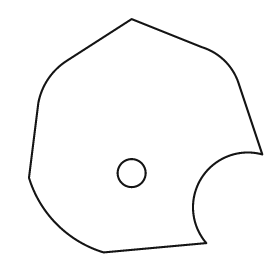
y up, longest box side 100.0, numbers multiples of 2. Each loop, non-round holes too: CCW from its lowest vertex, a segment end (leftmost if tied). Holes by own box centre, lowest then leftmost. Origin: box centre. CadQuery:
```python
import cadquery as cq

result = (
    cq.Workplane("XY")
    .moveTo(-18.0, -50.0)
    .lineTo(26.0, -46.0)
    .threePointArc((24.0, -18.0), (50.0, -8.0))
    .lineTo(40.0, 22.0)
    .threePointArc((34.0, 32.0), (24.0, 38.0))
    .lineTo(-6.0, 50.0)
    .lineTo(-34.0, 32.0)
    .threePointArc((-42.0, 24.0), (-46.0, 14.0))
    .lineTo(-50.0, -18.0)
    .threePointArc((-38.0, -38.0), (-18.0, -50.0))
    .close()
    .moveTo(-6.0, -16.0)
    .circle(6.0)
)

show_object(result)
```